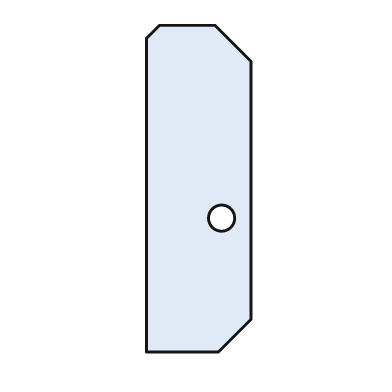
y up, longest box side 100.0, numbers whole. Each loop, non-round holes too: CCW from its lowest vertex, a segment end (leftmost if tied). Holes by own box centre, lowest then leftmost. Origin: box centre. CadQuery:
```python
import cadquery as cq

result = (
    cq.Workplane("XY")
    .moveTo(-16.0, -50.0)
    .lineTo(6.0, -50.0)
    .lineTo(16.0, -40.0)
    .lineTo(16.0, 39.0)
    .lineTo(5.0, 50.0)
    .lineTo(-12.0, 50.0)
    .lineTo(-16.0, 46.0)
    .close()
    .moveTo(7.0, -9.0)
    .circle(4.0)
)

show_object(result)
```